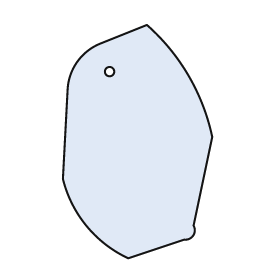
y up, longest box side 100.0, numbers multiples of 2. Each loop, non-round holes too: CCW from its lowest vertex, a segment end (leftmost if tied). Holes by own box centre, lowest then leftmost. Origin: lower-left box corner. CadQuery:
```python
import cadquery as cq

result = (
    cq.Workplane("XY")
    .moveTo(28.0, 0.0)
    .lineTo(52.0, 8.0)
    .threePointArc((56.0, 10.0), (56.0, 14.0))
    .lineTo(64.0, 52.0)
    .threePointArc((54.0, 78.0), (36.0, 100.0))
    .lineTo(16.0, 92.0)
    .threePointArc((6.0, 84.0), (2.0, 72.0))
    .lineTo(0.0, 34.0)
    .threePointArc((10.0, 14.0), (28.0, 0.0))
    .close()
    .moveTo(20.0, 80.0)
    .circle(2.0)
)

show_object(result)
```